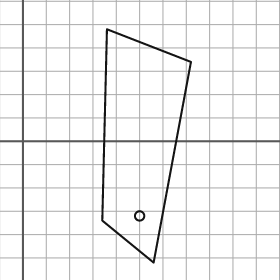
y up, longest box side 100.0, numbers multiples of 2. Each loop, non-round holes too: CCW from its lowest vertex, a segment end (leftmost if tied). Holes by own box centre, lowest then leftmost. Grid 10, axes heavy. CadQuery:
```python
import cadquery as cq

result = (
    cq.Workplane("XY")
    .moveTo(56.0, -52.0)
    .lineTo(72.0, 34.0)
    .lineTo(36.0, 48.0)
    .lineTo(34.0, -34.0)
    .close()
    .moveTo(50.0, -32.0)
    .circle(2.0)
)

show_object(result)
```